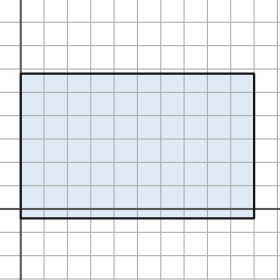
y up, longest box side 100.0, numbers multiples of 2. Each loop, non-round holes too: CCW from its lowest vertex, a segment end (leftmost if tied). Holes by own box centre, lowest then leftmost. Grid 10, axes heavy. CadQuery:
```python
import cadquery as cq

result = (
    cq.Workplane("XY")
    .moveTo(0.0, -4.0)
    .lineTo(100.0, -4.0)
    .lineTo(100.0, 58.0)
    .lineTo(0.0, 58.0)
    .close()
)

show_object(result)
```